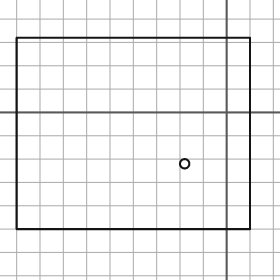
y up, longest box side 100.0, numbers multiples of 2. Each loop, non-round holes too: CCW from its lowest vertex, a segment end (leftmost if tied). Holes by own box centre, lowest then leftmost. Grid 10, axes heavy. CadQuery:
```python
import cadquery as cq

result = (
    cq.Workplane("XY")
    .moveTo(-90.0, -50.0)
    .lineTo(10.0, -50.0)
    .lineTo(10.0, 32.0)
    .lineTo(-90.0, 32.0)
    .close()
    .moveTo(-18.0, -22.0)
    .circle(2.0)
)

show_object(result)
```